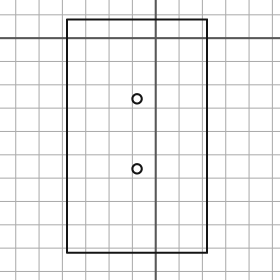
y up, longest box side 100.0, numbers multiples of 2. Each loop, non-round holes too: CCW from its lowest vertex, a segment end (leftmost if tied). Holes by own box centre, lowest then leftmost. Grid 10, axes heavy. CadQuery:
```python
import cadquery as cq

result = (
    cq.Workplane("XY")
    .moveTo(-38.0, -92.0)
    .lineTo(22.0, -92.0)
    .lineTo(22.0, 8.0)
    .lineTo(-38.0, 8.0)
    .close()
    .moveTo(-8.0, -56.0)
    .circle(2.0)
    .moveTo(-8.0, -26.0)
    .circle(2.0)
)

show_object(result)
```